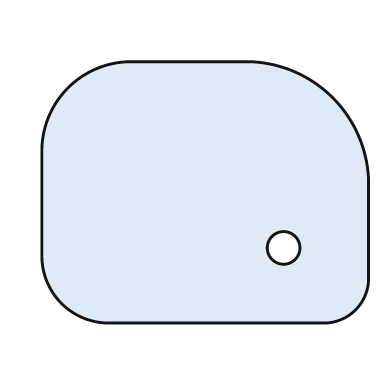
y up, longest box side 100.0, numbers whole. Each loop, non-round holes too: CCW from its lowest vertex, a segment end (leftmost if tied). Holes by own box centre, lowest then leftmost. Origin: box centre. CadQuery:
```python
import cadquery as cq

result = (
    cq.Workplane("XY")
    .moveTo(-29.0, -40.0)
    .lineTo(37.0, -40.0)
    .threePointArc((46.0, -36.0), (50.0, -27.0))
    .lineTo(50.0, 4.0)
    .threePointArc((39.0, 29.0), (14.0, 40.0))
    .lineTo(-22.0, 40.0)
    .threePointArc((-42.0, 32.0), (-50.0, 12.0))
    .lineTo(-50.0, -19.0)
    .threePointArc((-44.0, -34.0), (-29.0, -40.0))
    .close()
    .moveTo(24.0, -17.0)
    .circle(5.0)
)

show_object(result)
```